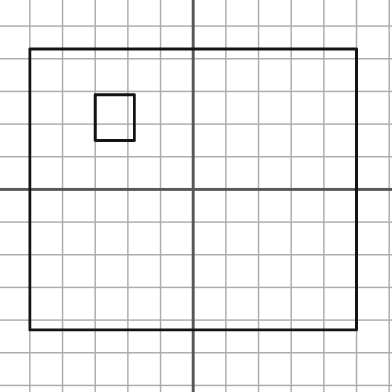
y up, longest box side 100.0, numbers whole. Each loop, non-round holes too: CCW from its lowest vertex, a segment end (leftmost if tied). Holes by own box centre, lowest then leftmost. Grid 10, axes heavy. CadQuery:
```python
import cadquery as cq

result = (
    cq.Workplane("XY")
    .moveTo(-50.0, -43.0)
    .lineTo(50.0, -43.0)
    .lineTo(50.0, 43.0)
    .lineTo(-50.0, 43.0)
    .close()
    .moveTo(-30.0, 15.0)
    .lineTo(-18.0, 15.0)
    .lineTo(-18.0, 29.0)
    .lineTo(-30.0, 29.0)
    .close()
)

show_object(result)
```